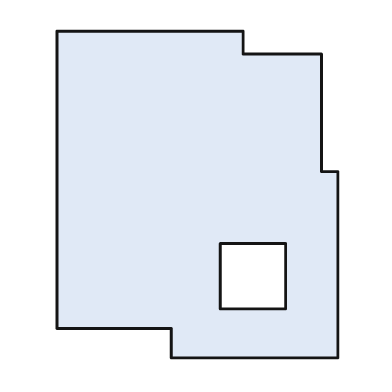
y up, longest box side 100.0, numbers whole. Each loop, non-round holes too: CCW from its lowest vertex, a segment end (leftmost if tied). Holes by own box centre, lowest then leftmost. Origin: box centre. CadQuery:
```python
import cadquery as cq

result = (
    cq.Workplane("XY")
    .moveTo(-8.0, -50.0)
    .lineTo(43.0, -50.0)
    .lineTo(43.0, 7.0)
    .lineTo(38.0, 7.0)
    .lineTo(38.0, 43.0)
    .lineTo(14.0, 43.0)
    .lineTo(14.0, 50.0)
    .lineTo(-43.0, 50.0)
    .lineTo(-43.0, -41.0)
    .lineTo(-8.0, -41.0)
    .close()
    .moveTo(7.0, -35.0)
    .lineTo(27.0, -35.0)
    .lineTo(27.0, -15.0)
    .lineTo(7.0, -15.0)
    .close()
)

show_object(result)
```